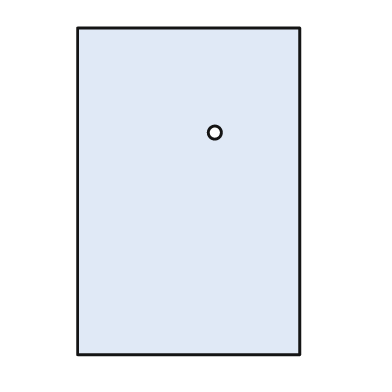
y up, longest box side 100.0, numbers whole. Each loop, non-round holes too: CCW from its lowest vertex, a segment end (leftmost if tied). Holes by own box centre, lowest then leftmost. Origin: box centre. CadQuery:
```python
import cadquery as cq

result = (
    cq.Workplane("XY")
    .moveTo(-34.0, -50.0)
    .lineTo(34.0, -50.0)
    .lineTo(34.0, 50.0)
    .lineTo(-34.0, 50.0)
    .close()
    .moveTo(8.0, 18.0)
    .circle(2.0)
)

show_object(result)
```